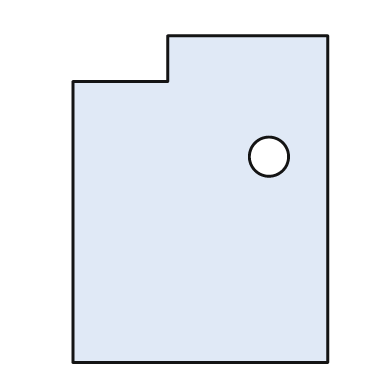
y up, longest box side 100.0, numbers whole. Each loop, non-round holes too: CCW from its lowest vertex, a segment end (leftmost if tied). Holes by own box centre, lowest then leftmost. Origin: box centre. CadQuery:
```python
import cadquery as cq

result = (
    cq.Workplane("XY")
    .moveTo(-39.0, -50.0)
    .lineTo(39.0, -50.0)
    .lineTo(39.0, 50.0)
    .lineTo(-10.0, 50.0)
    .lineTo(-10.0, 36.0)
    .lineTo(-39.0, 36.0)
    .close()
    .moveTo(21.0, 13.0)
    .circle(6.0)
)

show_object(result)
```